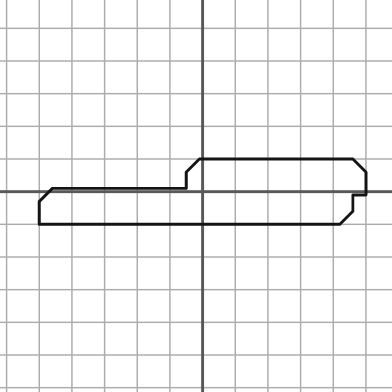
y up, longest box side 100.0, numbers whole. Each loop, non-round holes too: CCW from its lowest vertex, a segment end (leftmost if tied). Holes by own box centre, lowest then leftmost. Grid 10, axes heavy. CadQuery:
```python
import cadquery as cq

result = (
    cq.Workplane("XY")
    .moveTo(-50.0, -10.0)
    .lineTo(42.0, -10.0)
    .lineTo(46.0, -6.0)
    .lineTo(46.0, -1.0)
    .lineTo(50.0, -1.0)
    .lineTo(50.0, 6.0)
    .lineTo(46.0, 10.0)
    .lineTo(-1.0, 10.0)
    .lineTo(-5.0, 6.0)
    .lineTo(-5.0, 1.0)
    .lineTo(-46.0, 1.0)
    .lineTo(-50.0, -3.0)
    .close()
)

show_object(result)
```